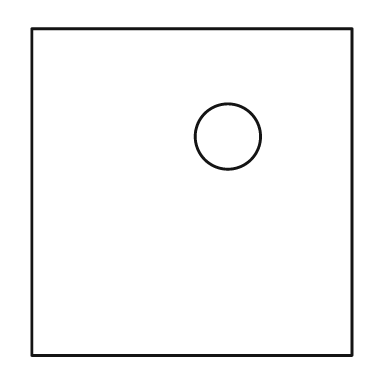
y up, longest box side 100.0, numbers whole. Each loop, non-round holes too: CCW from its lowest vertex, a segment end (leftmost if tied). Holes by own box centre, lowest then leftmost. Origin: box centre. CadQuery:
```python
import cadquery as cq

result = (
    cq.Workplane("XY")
    .moveTo(-49.0, -50.0)
    .lineTo(49.0, -50.0)
    .lineTo(49.0, 50.0)
    .lineTo(-49.0, 50.0)
    .close()
    .moveTo(11.0, 17.0)
    .circle(10.0)
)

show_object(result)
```